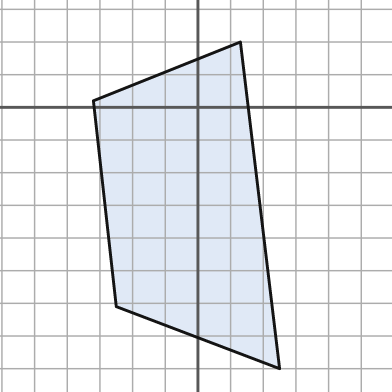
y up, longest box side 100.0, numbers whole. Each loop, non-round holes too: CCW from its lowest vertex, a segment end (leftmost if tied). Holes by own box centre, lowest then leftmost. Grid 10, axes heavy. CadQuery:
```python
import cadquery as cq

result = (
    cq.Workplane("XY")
    .moveTo(25.0, -80.0)
    .lineTo(13.0, 20.0)
    .lineTo(-32.0, 2.0)
    .lineTo(-25.0, -61.0)
    .close()
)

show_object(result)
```